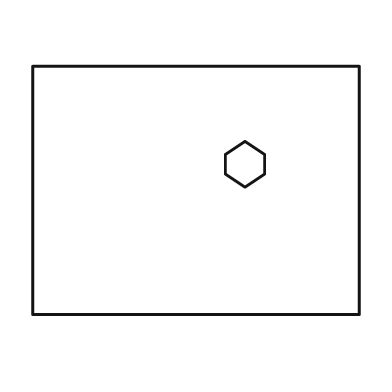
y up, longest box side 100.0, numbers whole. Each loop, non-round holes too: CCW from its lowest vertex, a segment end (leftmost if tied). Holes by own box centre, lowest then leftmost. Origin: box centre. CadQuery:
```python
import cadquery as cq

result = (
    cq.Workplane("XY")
    .moveTo(-50.0, -38.0)
    .lineTo(50.0, -38.0)
    .lineTo(50.0, 38.0)
    .lineTo(-50.0, 38.0)
    .close()
    .moveTo(15.0, 1.0)
    .lineTo(21.0, 5.0)
    .lineTo(21.0, 11.0)
    .lineTo(15.0, 15.0)
    .lineTo(9.0, 11.0)
    .lineTo(9.0, 5.0)
    .close()
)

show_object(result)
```